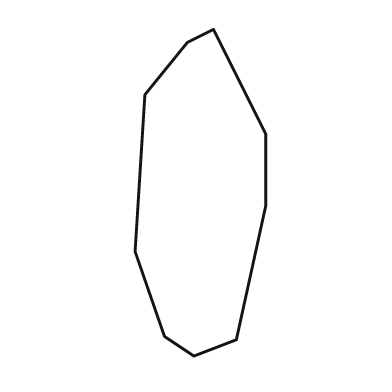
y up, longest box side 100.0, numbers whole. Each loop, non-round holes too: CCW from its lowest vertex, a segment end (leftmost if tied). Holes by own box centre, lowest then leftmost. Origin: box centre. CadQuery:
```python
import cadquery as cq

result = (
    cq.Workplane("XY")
    .moveTo(-2.0, -50.0)
    .lineTo(11.0, -45.0)
    .lineTo(20.0, -4.0)
    .lineTo(20.0, 18.0)
    .lineTo(4.0, 50.0)
    .lineTo(-4.0, 46.0)
    .lineTo(-17.0, 30.0)
    .lineTo(-20.0, -18.0)
    .lineTo(-11.0, -44.0)
    .close()
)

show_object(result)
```